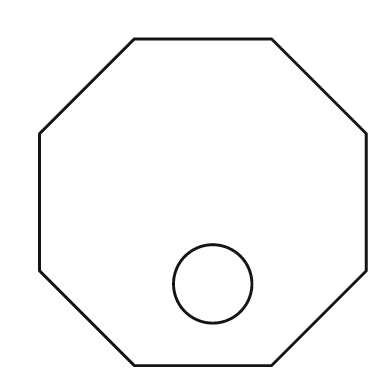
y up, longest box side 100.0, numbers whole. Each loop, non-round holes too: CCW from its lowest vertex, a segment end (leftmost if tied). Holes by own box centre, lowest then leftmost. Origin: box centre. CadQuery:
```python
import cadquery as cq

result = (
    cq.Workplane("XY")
    .moveTo(-21.0, -50.0)
    .lineTo(21.0, -50.0)
    .lineTo(50.0, -21.0)
    .lineTo(50.0, 21.0)
    .lineTo(21.0, 50.0)
    .lineTo(-21.0, 50.0)
    .lineTo(-50.0, 21.0)
    .lineTo(-50.0, -21.0)
    .close()
    .moveTo(3.0, -25.0)
    .circle(12.0)
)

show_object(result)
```